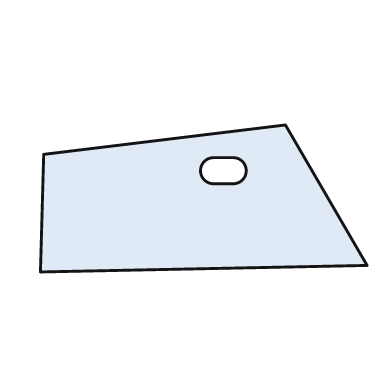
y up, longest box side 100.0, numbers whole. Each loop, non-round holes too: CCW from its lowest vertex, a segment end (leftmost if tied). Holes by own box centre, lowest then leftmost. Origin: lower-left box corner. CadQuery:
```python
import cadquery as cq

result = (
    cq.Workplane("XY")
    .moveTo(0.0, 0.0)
    .lineTo(100.0, 2.0)
    .lineTo(75.0, 45.0)
    .lineTo(1.0, 36.0)
    .close()
    .moveTo(53.0, 27.0)
    .lineTo(59.0, 27.0)
    .threePointArc((63.0, 31.0), (59.0, 35.0))
    .lineTo(53.0, 35.0)
    .threePointArc((49.0, 31.0), (53.0, 27.0))
    .close()
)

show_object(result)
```